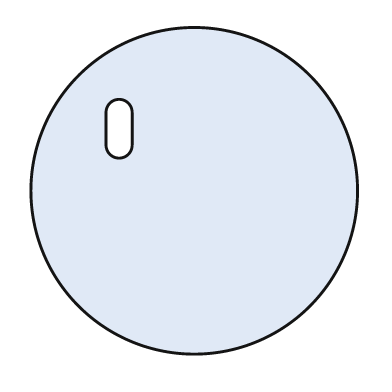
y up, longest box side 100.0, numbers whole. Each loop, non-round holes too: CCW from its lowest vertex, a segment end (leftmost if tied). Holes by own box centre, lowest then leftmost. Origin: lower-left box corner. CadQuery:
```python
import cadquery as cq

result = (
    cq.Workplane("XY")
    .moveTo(50.0, 50.0)
    .circle(50.0)
    .moveTo(23.0, 64.0)
    .threePointArc((27.0, 60.0), (31.0, 64.0))
    .lineTo(31.0, 74.0)
    .threePointArc((27.0, 78.0), (23.0, 74.0))
    .close()
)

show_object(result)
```